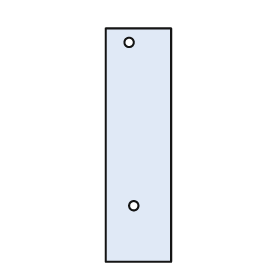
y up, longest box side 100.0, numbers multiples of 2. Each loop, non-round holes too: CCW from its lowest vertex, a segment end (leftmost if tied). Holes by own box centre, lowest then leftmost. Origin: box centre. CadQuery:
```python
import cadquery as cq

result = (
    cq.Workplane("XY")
    .moveTo(-14.0, -50.0)
    .lineTo(14.0, -50.0)
    .lineTo(14.0, 50.0)
    .lineTo(-14.0, 50.0)
    .close()
    .moveTo(-2.0, -26.0)
    .circle(2.0)
    .moveTo(-4.0, 44.0)
    .circle(2.0)
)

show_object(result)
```